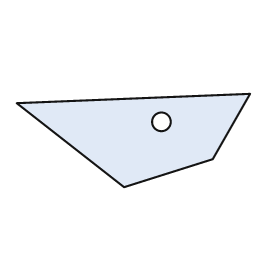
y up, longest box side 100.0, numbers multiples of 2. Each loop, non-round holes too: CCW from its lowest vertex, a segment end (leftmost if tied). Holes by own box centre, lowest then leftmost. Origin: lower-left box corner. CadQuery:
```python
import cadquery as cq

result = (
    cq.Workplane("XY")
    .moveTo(46.0, 0.0)
    .lineTo(84.0, 12.0)
    .lineTo(100.0, 40.0)
    .lineTo(0.0, 36.0)
    .close()
    .moveTo(62.0, 28.0)
    .circle(4.0)
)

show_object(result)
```